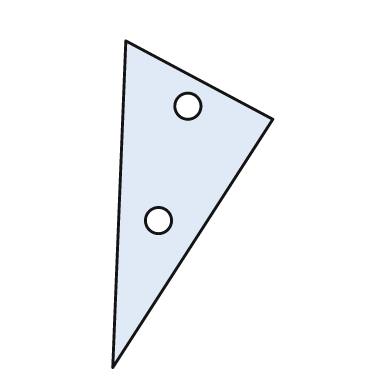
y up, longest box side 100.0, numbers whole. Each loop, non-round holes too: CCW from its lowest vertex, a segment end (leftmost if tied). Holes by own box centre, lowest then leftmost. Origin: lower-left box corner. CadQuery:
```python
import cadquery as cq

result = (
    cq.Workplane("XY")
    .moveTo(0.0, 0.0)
    .lineTo(49.0, 76.0)
    .lineTo(4.0, 100.0)
    .close()
    .moveTo(14.0, 45.0)
    .circle(4.0)
    .moveTo(23.0, 80.0)
    .circle(4.0)
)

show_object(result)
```